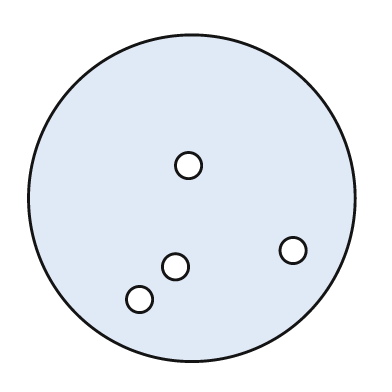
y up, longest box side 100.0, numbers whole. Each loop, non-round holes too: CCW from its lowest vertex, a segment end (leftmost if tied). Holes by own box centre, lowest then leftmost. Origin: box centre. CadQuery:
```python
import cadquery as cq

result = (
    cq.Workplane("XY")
    .moveTo(0.0, 0.0)
    .circle(50.0)
    .moveTo(-16.0, -31.0)
    .circle(4.0)
    .moveTo(-5.0, -21.0)
    .circle(4.0)
    .moveTo(31.0, -16.0)
    .circle(4.0)
    .moveTo(-1.0, 10.0)
    .circle(4.0)
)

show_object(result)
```